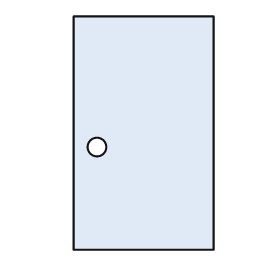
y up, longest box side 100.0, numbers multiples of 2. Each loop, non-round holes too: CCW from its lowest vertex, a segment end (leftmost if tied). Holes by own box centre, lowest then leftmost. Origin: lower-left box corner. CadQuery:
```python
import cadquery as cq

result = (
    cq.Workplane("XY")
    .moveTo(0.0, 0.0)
    .lineTo(60.0, 0.0)
    .lineTo(60.0, 100.0)
    .lineTo(0.0, 100.0)
    .close()
    .moveTo(10.0, 44.0)
    .circle(4.0)
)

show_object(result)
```